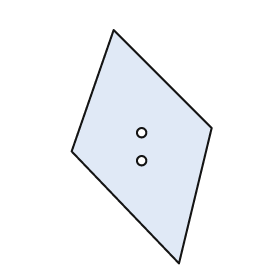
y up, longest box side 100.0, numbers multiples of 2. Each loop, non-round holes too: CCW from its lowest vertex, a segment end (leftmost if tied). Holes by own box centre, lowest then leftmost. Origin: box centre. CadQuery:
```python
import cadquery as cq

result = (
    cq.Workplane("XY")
    .moveTo(16.0, -50.0)
    .lineTo(30.0, 8.0)
    .lineTo(-12.0, 50.0)
    .lineTo(-30.0, -2.0)
    .close()
    .moveTo(0.0, -6.0)
    .circle(2.0)
    .moveTo(0.0, 6.0)
    .circle(2.0)
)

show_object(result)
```